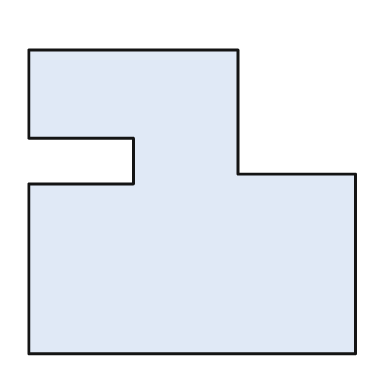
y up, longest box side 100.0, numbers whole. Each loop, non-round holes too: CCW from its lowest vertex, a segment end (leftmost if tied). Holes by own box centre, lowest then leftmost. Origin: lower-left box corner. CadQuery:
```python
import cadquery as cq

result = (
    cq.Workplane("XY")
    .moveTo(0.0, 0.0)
    .lineTo(100.0, 0.0)
    .lineTo(100.0, 55.0)
    .lineTo(64.0, 55.0)
    .lineTo(64.0, 93.0)
    .lineTo(0.0, 93.0)
    .lineTo(0.0, 66.0)
    .lineTo(32.0, 66.0)
    .lineTo(32.0, 52.0)
    .lineTo(0.0, 52.0)
    .close()
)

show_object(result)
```